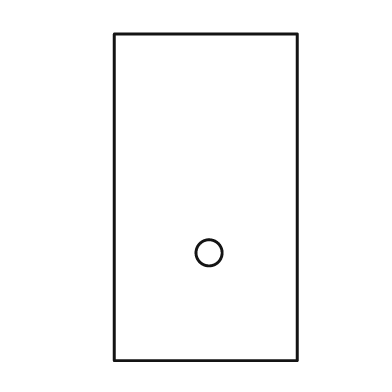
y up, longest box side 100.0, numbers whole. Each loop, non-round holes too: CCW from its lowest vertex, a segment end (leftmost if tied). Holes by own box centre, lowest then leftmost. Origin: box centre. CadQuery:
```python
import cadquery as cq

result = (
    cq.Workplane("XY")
    .moveTo(-28.0, -50.0)
    .lineTo(28.0, -50.0)
    .lineTo(28.0, 50.0)
    .lineTo(-28.0, 50.0)
    .close()
    .moveTo(1.0, -17.0)
    .circle(4.0)
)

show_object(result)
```